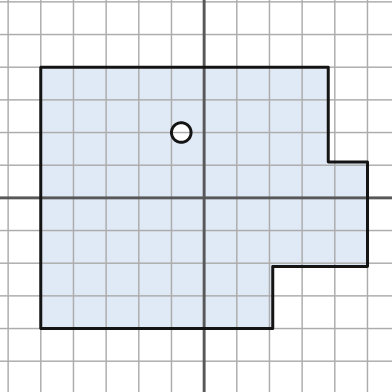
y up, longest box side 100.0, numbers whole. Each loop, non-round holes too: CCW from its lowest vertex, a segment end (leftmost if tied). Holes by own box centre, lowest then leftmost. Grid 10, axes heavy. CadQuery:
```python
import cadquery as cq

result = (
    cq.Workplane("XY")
    .moveTo(-50.0, -40.0)
    .lineTo(21.0, -40.0)
    .lineTo(21.0, -21.0)
    .lineTo(50.0, -21.0)
    .lineTo(50.0, 11.0)
    .lineTo(38.0, 11.0)
    .lineTo(38.0, 40.0)
    .lineTo(-50.0, 40.0)
    .close()
    .moveTo(-7.0, 20.0)
    .circle(3.0)
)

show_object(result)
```